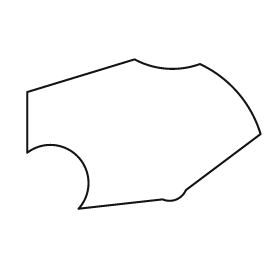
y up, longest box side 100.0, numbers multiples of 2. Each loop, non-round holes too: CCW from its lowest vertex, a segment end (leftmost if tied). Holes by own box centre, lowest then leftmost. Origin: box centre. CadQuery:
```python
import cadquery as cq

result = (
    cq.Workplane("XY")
    .moveTo(-28.0, -32.0)
    .lineTo(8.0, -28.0)
    .threePointArc((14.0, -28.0), (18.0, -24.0))
    .lineTo(50.0, 0.0)
    .threePointArc((40.0, 18.0), (24.0, 30.0))
    .threePointArc((10.0, 28.0), (-4.0, 32.0))
    .lineTo(-50.0, 18.0)
    .lineTo(-50.0, -8.0)
    .threePointArc((-28.0, -10.0), (-28.0, -32.0))
    .close()
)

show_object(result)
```